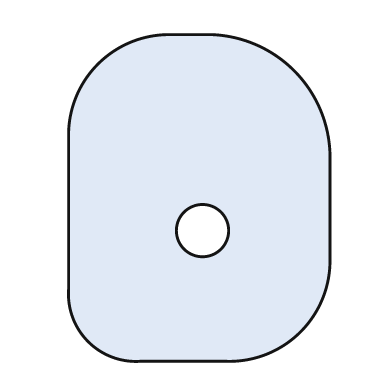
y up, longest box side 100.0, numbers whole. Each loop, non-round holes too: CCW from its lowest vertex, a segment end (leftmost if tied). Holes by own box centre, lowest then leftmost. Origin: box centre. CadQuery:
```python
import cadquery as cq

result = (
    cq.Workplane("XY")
    .moveTo(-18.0, -50.0)
    .lineTo(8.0, -50.0)
    .threePointArc((31.0, -41.0), (40.0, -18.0))
    .lineTo(40.0, 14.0)
    .threePointArc((29.0, 39.0), (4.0, 50.0))
    .lineTo(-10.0, 50.0)
    .threePointArc((-31.0, 41.0), (-40.0, 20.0))
    .lineTo(-40.0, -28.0)
    .threePointArc((-34.0, -44.0), (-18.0, -50.0))
    .close()
    .moveTo(1.0, -10.0)
    .circle(8.0)
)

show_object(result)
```